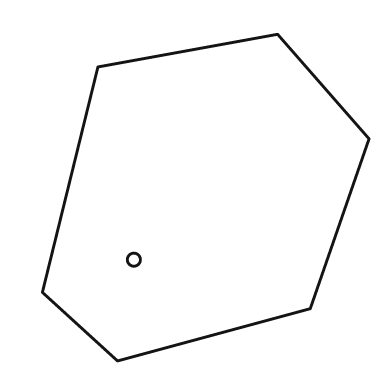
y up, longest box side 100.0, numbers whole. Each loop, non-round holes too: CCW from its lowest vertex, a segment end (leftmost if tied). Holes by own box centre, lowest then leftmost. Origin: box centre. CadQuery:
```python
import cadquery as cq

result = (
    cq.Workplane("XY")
    .moveTo(-27.0, -50.0)
    .lineTo(32.0, -34.0)
    .lineTo(50.0, 18.0)
    .lineTo(22.0, 50.0)
    .lineTo(-33.0, 40.0)
    .lineTo(-50.0, -29.0)
    .close()
    .moveTo(-22.0, -19.0)
    .circle(2.0)
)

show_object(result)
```